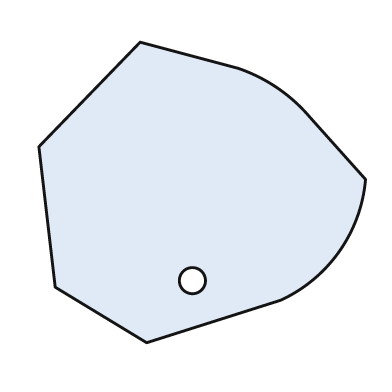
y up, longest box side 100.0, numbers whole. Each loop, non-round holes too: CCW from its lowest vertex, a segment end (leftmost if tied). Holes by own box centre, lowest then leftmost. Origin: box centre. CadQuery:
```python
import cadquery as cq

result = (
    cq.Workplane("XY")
    .moveTo(-17.0, -46.0)
    .lineTo(24.0, -33.0)
    .threePointArc((42.0, -18.0), (50.0, 4.0))
    .lineTo(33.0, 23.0)
    .threePointArc((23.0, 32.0), (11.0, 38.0))
    .lineTo(-19.0, 46.0)
    .lineTo(-50.0, 14.0)
    .lineTo(-45.0, -29.0)
    .close()
    .moveTo(-3.0, -27.0)
    .circle(4.0)
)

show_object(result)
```